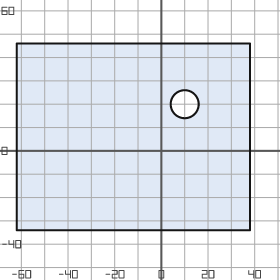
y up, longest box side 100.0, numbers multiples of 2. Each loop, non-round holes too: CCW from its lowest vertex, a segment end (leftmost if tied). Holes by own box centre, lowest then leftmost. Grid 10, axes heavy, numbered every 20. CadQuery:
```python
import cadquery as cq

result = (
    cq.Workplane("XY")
    .moveTo(-62.0, -34.0)
    .lineTo(38.0, -34.0)
    .lineTo(38.0, 46.0)
    .lineTo(-62.0, 46.0)
    .close()
    .moveTo(10.0, 20.0)
    .circle(6.0)
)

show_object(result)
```